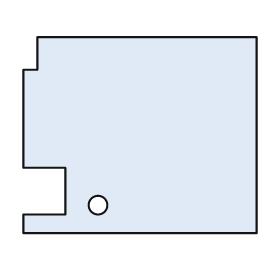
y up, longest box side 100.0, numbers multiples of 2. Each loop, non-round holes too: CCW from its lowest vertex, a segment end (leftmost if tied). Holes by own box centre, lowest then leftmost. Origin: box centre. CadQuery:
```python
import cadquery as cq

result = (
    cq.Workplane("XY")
    .moveTo(-50.0, -42.0)
    .lineTo(50.0, -42.0)
    .lineTo(50.0, 42.0)
    .lineTo(-44.0, 42.0)
    .lineTo(-44.0, 28.0)
    .lineTo(-50.0, 28.0)
    .lineTo(-50.0, -14.0)
    .lineTo(-32.0, -14.0)
    .lineTo(-32.0, -34.0)
    .lineTo(-50.0, -34.0)
    .close()
    .moveTo(-18.0, -30.0)
    .circle(4.0)
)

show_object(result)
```